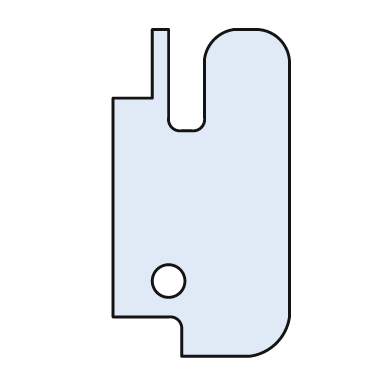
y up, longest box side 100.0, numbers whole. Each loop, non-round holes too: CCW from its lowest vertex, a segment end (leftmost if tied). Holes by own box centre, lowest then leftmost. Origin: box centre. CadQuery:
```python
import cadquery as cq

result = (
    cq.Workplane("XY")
    .moveTo(-6.0, -50.0)
    .lineTo(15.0, -50.0)
    .threePointArc((23.0, -46.0), (27.0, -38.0))
    .lineTo(27.0, 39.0)
    .threePointArc((24.0, 47.0), (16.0, 50.0))
    .lineTo(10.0, 50.0)
    .threePointArc((4.0, 47.0), (1.0, 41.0))
    .lineTo(1.0, 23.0)
    .threePointArc((0.0, 20.0), (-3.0, 19.0))
    .lineTo(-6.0, 19.0)
    .threePointArc((-9.0, 20.0), (-10.0, 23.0))
    .lineTo(-10.0, 50.0)
    .lineTo(-15.0, 50.0)
    .lineTo(-15.0, 29.0)
    .lineTo(-27.0, 29.0)
    .lineTo(-27.0, -38.0)
    .lineTo(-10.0, -38.0)
    .threePointArc((-7.0, -39.0), (-6.0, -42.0))
    .close()
    .moveTo(-10.0, -27.0)
    .circle(5.0)
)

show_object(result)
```